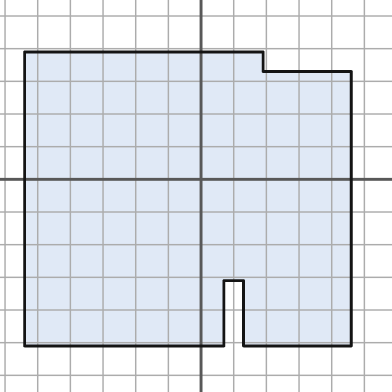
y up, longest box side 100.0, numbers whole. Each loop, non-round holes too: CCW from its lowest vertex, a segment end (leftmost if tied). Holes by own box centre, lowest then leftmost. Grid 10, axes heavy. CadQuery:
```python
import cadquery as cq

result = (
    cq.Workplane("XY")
    .moveTo(-54.0, -51.0)
    .lineTo(7.0, -51.0)
    .lineTo(7.0, -31.0)
    .lineTo(13.0, -31.0)
    .lineTo(13.0, -51.0)
    .lineTo(46.0, -51.0)
    .lineTo(46.0, 33.0)
    .lineTo(19.0, 33.0)
    .lineTo(19.0, 39.0)
    .lineTo(-54.0, 39.0)
    .close()
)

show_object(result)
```